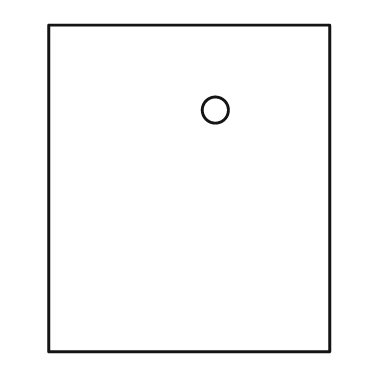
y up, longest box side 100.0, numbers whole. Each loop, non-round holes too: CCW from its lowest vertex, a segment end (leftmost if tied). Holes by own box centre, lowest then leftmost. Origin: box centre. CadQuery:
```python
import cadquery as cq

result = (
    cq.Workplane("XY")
    .moveTo(-43.0, -50.0)
    .lineTo(43.0, -50.0)
    .lineTo(43.0, 50.0)
    .lineTo(-43.0, 50.0)
    .close()
    .moveTo(8.0, 24.0)
    .circle(4.0)
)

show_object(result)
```